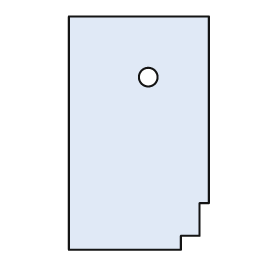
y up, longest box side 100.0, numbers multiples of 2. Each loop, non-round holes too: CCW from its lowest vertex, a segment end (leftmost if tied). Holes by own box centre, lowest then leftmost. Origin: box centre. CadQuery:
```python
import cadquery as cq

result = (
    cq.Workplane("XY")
    .moveTo(-30.0, -50.0)
    .lineTo(18.0, -50.0)
    .lineTo(18.0, -44.0)
    .lineTo(26.0, -44.0)
    .lineTo(26.0, -30.0)
    .lineTo(30.0, -30.0)
    .lineTo(30.0, 50.0)
    .lineTo(-30.0, 50.0)
    .close()
    .moveTo(4.0, 24.0)
    .circle(4.0)
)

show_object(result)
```